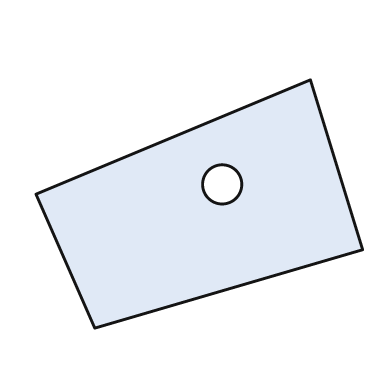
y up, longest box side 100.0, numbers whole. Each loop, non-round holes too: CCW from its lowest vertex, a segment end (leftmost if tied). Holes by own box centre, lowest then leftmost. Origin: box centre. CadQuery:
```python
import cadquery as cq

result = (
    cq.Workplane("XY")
    .moveTo(-32.0, -38.0)
    .lineTo(50.0, -14.0)
    .lineTo(34.0, 38.0)
    .lineTo(-50.0, 3.0)
    .close()
    .moveTo(7.0, 6.0)
    .circle(6.0)
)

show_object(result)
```